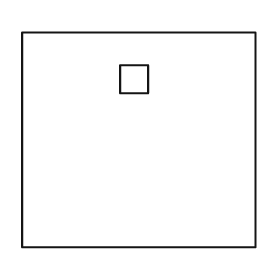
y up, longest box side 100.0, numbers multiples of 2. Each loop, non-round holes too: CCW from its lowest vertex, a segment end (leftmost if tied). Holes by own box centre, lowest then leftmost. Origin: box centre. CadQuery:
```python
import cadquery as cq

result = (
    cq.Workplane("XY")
    .moveTo(-50.0, -46.0)
    .lineTo(50.0, -46.0)
    .lineTo(50.0, 46.0)
    .lineTo(-50.0, 46.0)
    .close()
    .moveTo(-8.0, 20.0)
    .lineTo(4.0, 20.0)
    .lineTo(4.0, 32.0)
    .lineTo(-8.0, 32.0)
    .close()
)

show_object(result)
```